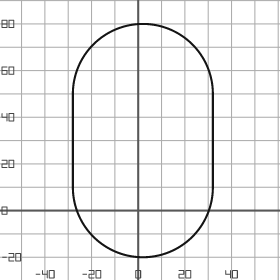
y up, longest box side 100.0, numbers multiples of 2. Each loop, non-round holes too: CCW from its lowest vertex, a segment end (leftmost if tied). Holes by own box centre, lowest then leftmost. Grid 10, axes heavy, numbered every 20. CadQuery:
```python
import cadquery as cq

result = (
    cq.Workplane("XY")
    .moveTo(-28.0, 10.0)
    .threePointArc((2.0, -20.0), (32.0, 10.0))
    .lineTo(32.0, 50.0)
    .threePointArc((2.0, 80.0), (-28.0, 50.0))
    .close()
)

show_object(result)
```